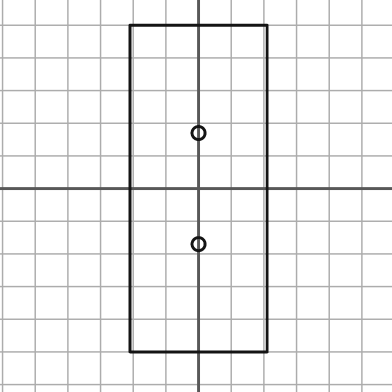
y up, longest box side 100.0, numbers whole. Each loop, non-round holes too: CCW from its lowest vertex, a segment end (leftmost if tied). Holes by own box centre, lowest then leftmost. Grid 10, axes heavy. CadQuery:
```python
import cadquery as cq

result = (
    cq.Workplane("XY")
    .moveTo(-21.0, -50.0)
    .lineTo(21.0, -50.0)
    .lineTo(21.0, 50.0)
    .lineTo(-21.0, 50.0)
    .close()
    .moveTo(0.0, -17.0)
    .circle(2.0)
    .moveTo(0.0, 17.0)
    .circle(2.0)
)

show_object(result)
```